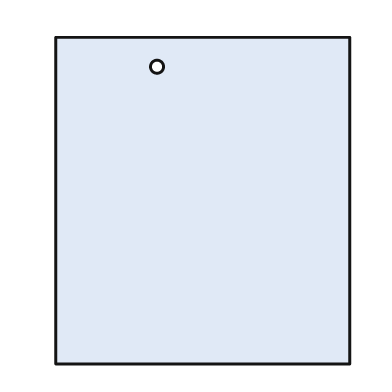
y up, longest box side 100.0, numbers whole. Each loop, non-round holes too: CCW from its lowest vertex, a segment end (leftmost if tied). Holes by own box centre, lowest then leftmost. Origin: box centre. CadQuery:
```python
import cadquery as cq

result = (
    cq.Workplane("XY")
    .moveTo(-45.0, -50.0)
    .lineTo(45.0, -50.0)
    .lineTo(45.0, 50.0)
    .lineTo(-45.0, 50.0)
    .close()
    .moveTo(-14.0, 41.0)
    .circle(2.0)
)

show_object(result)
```